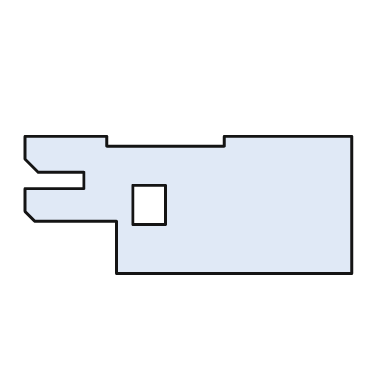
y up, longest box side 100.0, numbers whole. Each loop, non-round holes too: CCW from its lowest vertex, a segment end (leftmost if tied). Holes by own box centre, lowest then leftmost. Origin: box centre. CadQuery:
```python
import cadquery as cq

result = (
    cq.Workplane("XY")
    .moveTo(-22.0, -21.0)
    .lineTo(50.0, -21.0)
    .lineTo(50.0, 21.0)
    .lineTo(11.0, 21.0)
    .lineTo(11.0, 18.0)
    .lineTo(-25.0, 18.0)
    .lineTo(-25.0, 21.0)
    .lineTo(-50.0, 21.0)
    .lineTo(-50.0, 14.0)
    .lineTo(-46.0, 10.0)
    .lineTo(-32.0, 10.0)
    .lineTo(-32.0, 5.0)
    .lineTo(-50.0, 5.0)
    .lineTo(-50.0, -2.0)
    .lineTo(-47.0, -5.0)
    .lineTo(-22.0, -5.0)
    .close()
    .moveTo(-17.0, -6.0)
    .lineTo(-7.0, -6.0)
    .lineTo(-7.0, 6.0)
    .lineTo(-17.0, 6.0)
    .close()
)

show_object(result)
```